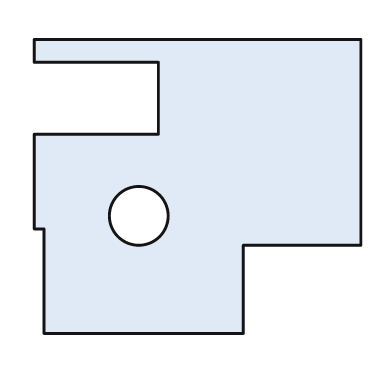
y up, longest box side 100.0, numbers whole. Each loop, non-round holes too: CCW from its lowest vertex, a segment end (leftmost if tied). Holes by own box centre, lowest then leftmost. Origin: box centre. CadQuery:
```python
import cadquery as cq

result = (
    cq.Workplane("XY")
    .moveTo(-47.0, -45.0)
    .lineTo(14.0, -45.0)
    .lineTo(14.0, -18.0)
    .lineTo(50.0, -18.0)
    .lineTo(50.0, 45.0)
    .lineTo(-50.0, 45.0)
    .lineTo(-50.0, 38.0)
    .lineTo(-12.0, 38.0)
    .lineTo(-12.0, 16.0)
    .lineTo(-50.0, 16.0)
    .lineTo(-50.0, -13.0)
    .lineTo(-47.0, -13.0)
    .close()
    .moveTo(-18.0, -9.0)
    .circle(9.0)
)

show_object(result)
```